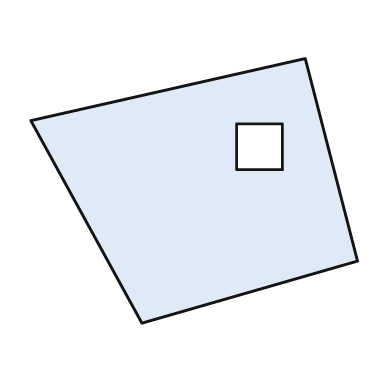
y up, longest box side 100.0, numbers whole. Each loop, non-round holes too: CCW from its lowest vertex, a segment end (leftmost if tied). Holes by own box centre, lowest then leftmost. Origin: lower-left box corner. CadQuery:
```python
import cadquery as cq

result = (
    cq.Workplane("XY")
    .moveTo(34.0, 0.0)
    .lineTo(100.0, 19.0)
    .lineTo(84.0, 81.0)
    .lineTo(0.0, 62.0)
    .close()
    .moveTo(63.0, 47.0)
    .lineTo(77.0, 47.0)
    .lineTo(77.0, 61.0)
    .lineTo(63.0, 61.0)
    .close()
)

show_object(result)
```